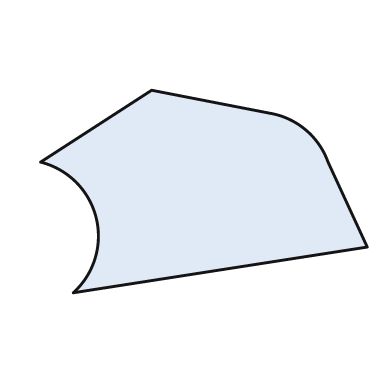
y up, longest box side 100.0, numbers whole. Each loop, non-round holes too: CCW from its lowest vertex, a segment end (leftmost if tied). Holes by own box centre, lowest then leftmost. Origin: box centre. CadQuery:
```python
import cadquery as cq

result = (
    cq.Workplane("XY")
    .moveTo(-40.0, -31.0)
    .lineTo(50.0, -17.0)
    .lineTo(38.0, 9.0)
    .threePointArc((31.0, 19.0), (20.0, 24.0))
    .lineTo(-16.0, 31.0)
    .lineTo(-50.0, 9.0)
    .threePointArc((-33.0, -8.0), (-40.0, -31.0))
    .close()
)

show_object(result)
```